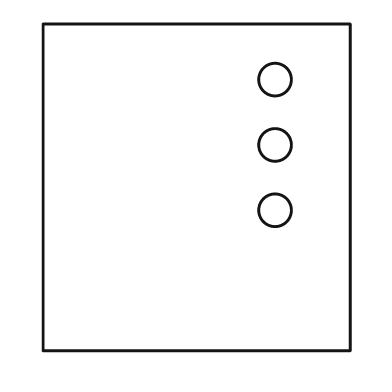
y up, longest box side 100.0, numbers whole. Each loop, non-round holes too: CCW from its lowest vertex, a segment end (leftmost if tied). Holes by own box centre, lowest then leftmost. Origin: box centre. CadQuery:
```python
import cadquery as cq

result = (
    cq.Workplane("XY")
    .moveTo(-47.0, -50.0)
    .lineTo(47.0, -50.0)
    .lineTo(47.0, 50.0)
    .lineTo(-47.0, 50.0)
    .close()
    .moveTo(24.0, -7.0)
    .circle(5.0)
    .moveTo(24.0, 13.0)
    .circle(5.0)
    .moveTo(24.0, 33.0)
    .circle(5.0)
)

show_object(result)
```